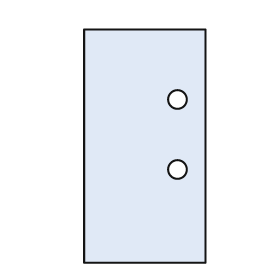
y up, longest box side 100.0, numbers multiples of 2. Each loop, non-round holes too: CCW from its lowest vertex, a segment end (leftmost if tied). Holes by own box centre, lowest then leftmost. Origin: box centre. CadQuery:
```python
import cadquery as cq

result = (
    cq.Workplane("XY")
    .moveTo(-26.0, -50.0)
    .lineTo(26.0, -50.0)
    .lineTo(26.0, 50.0)
    .lineTo(-26.0, 50.0)
    .close()
    .moveTo(14.0, -10.0)
    .circle(4.0)
    .moveTo(14.0, 20.0)
    .circle(4.0)
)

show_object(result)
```